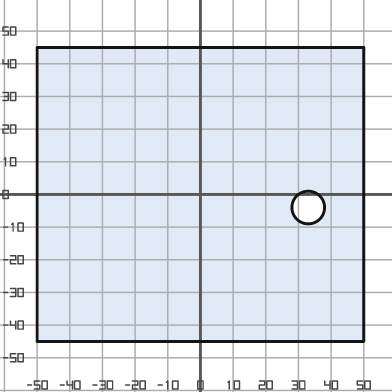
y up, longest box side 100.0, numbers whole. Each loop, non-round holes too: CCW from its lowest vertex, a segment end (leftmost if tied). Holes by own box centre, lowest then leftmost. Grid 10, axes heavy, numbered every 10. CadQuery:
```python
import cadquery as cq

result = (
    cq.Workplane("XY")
    .moveTo(-50.0, -45.0)
    .lineTo(50.0, -45.0)
    .lineTo(50.0, 45.0)
    .lineTo(-50.0, 45.0)
    .close()
    .moveTo(33.0, -4.0)
    .circle(5.0)
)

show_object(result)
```